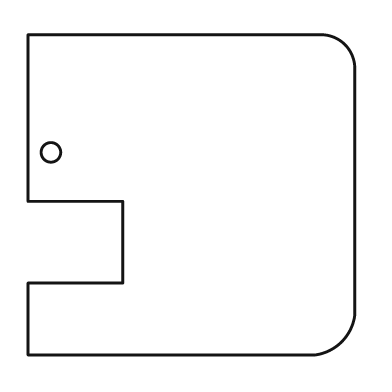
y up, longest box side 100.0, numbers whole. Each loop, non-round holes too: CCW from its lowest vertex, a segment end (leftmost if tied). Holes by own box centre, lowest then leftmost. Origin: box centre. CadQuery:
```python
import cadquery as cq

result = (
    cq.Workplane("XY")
    .moveTo(-50.0, -49.0)
    .lineTo(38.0, -49.0)
    .threePointArc((46.0, -45.0), (50.0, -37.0))
    .lineTo(50.0, 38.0)
    .threePointArc((47.0, 46.0), (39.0, 49.0))
    .lineTo(-50.0, 49.0)
    .lineTo(-50.0, -2.0)
    .lineTo(-21.0, -2.0)
    .lineTo(-21.0, -27.0)
    .lineTo(-50.0, -27.0)
    .close()
    .moveTo(-43.0, 13.0)
    .circle(3.0)
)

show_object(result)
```